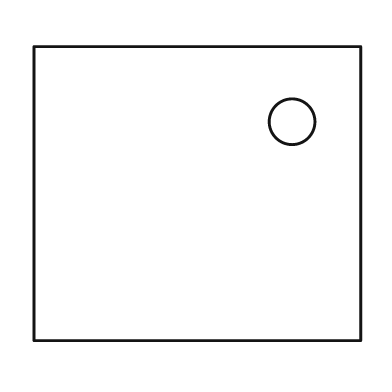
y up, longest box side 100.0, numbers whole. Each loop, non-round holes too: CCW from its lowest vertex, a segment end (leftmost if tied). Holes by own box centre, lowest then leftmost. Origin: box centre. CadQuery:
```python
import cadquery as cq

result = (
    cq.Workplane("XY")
    .moveTo(-50.0, -45.0)
    .lineTo(50.0, -45.0)
    .lineTo(50.0, 45.0)
    .lineTo(-50.0, 45.0)
    .close()
    .moveTo(29.0, 22.0)
    .circle(7.0)
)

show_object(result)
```